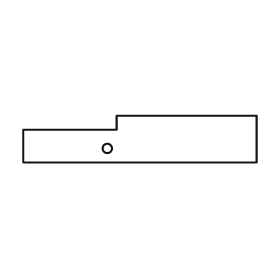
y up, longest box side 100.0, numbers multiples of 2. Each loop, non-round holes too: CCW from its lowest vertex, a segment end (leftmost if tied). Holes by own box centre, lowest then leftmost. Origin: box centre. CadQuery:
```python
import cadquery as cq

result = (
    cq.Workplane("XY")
    .moveTo(-50.0, -10.0)
    .lineTo(50.0, -10.0)
    .lineTo(50.0, 10.0)
    .lineTo(-10.0, 10.0)
    .lineTo(-10.0, 4.0)
    .lineTo(-50.0, 4.0)
    .close()
    .moveTo(-14.0, -4.0)
    .circle(2.0)
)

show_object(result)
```